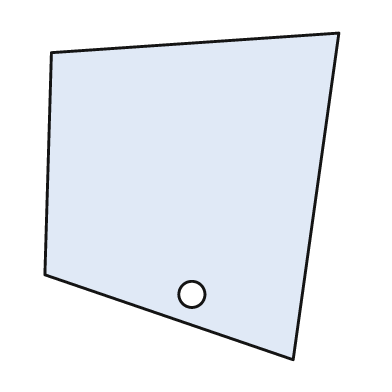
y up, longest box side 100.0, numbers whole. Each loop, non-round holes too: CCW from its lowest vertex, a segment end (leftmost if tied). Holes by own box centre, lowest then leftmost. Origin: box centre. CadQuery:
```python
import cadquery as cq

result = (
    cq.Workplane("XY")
    .moveTo(31.0, -50.0)
    .lineTo(45.0, 50.0)
    .lineTo(-43.0, 44.0)
    .lineTo(-45.0, -24.0)
    .close()
    .moveTo(0.0, -30.0)
    .circle(4.0)
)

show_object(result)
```